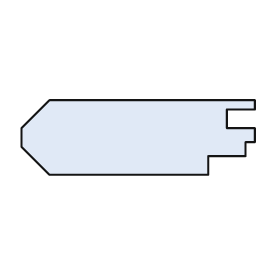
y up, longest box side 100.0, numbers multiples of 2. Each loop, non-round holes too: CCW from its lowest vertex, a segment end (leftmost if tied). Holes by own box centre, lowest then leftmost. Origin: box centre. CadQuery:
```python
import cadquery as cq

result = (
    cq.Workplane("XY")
    .moveTo(-38.0, -16.0)
    .lineTo(30.0, -16.0)
    .lineTo(30.0, -8.0)
    .lineTo(46.0, -8.0)
    .lineTo(46.0, -2.0)
    .lineTo(50.0, -2.0)
    .lineTo(50.0, 4.0)
    .lineTo(38.0, 4.0)
    .lineTo(38.0, 12.0)
    .lineTo(50.0, 12.0)
    .lineTo(50.0, 16.0)
    .lineTo(-38.0, 16.0)
    .lineTo(-50.0, 4.0)
    .lineTo(-50.0, -4.0)
    .close()
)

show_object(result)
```